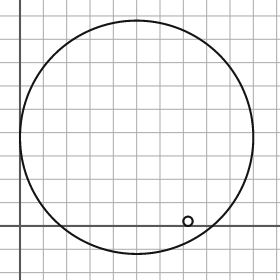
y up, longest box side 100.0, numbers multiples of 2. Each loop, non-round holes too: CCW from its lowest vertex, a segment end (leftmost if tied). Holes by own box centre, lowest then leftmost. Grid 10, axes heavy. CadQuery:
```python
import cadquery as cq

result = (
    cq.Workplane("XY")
    .moveTo(50.0, 38.0)
    .circle(50.0)
    .moveTo(72.0, 2.0)
    .circle(2.0)
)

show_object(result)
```